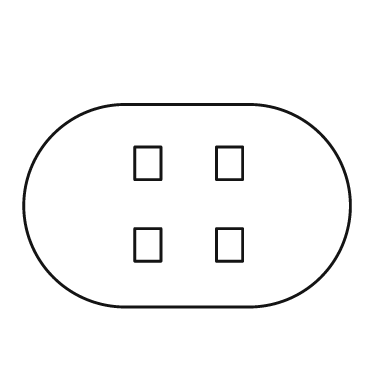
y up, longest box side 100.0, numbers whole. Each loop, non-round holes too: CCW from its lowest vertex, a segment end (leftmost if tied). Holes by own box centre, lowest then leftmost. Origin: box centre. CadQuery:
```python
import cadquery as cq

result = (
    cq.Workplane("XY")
    .moveTo(-19.0, -31.0)
    .lineTo(19.0, -31.0)
    .threePointArc((50.0, 0.0), (19.0, 31.0))
    .lineTo(-19.0, 31.0)
    .threePointArc((-50.0, 0.0), (-19.0, -31.0))
    .close()
    .moveTo(-16.0, -17.0)
    .lineTo(-8.0, -17.0)
    .lineTo(-8.0, -7.0)
    .lineTo(-16.0, -7.0)
    .close()
    .moveTo(9.0, -17.0)
    .lineTo(17.0, -17.0)
    .lineTo(17.0, -7.0)
    .lineTo(9.0, -7.0)
    .close()
    .moveTo(-16.0, 8.0)
    .lineTo(-8.0, 8.0)
    .lineTo(-8.0, 18.0)
    .lineTo(-16.0, 18.0)
    .close()
    .moveTo(9.0, 8.0)
    .lineTo(17.0, 8.0)
    .lineTo(17.0, 18.0)
    .lineTo(9.0, 18.0)
    .close()
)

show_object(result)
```